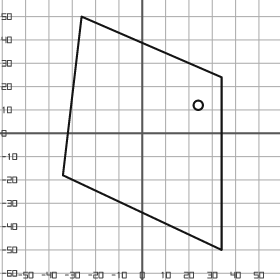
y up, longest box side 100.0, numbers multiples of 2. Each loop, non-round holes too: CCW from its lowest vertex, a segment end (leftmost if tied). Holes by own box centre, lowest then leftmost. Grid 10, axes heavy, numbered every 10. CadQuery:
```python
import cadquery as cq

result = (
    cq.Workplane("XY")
    .moveTo(34.0, -50.0)
    .lineTo(34.0, 24.0)
    .lineTo(-26.0, 50.0)
    .lineTo(-34.0, -18.0)
    .close()
    .moveTo(24.0, 12.0)
    .circle(2.0)
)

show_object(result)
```